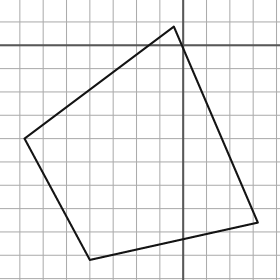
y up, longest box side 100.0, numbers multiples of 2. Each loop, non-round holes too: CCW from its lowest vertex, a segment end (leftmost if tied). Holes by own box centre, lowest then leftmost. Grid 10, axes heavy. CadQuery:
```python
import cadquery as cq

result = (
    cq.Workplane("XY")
    .moveTo(-40.0, -92.0)
    .lineTo(32.0, -76.0)
    .lineTo(-4.0, 8.0)
    .lineTo(-68.0, -40.0)
    .close()
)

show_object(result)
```